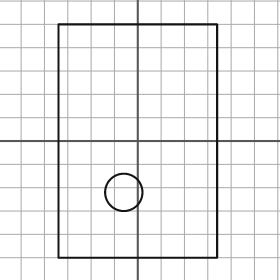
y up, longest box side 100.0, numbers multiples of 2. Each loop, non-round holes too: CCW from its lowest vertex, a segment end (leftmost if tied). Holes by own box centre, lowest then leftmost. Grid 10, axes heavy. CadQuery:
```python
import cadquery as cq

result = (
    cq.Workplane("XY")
    .moveTo(-34.0, -50.0)
    .lineTo(34.0, -50.0)
    .lineTo(34.0, 50.0)
    .lineTo(-34.0, 50.0)
    .close()
    .moveTo(-6.0, -22.0)
    .circle(8.0)
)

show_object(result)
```